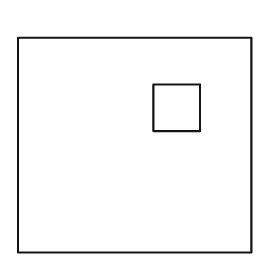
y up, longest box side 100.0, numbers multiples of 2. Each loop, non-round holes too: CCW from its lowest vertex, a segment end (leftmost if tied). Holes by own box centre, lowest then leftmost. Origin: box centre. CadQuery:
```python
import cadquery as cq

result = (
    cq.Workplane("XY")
    .moveTo(-50.0, -46.0)
    .lineTo(50.0, -46.0)
    .lineTo(50.0, 46.0)
    .lineTo(-50.0, 46.0)
    .close()
    .moveTo(8.0, 6.0)
    .lineTo(28.0, 6.0)
    .lineTo(28.0, 26.0)
    .lineTo(8.0, 26.0)
    .close()
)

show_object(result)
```